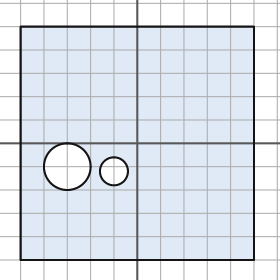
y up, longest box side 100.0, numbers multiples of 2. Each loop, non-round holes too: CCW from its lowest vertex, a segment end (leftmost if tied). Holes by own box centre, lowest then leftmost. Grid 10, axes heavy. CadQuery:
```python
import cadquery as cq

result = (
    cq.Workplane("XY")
    .moveTo(-50.0, -50.0)
    .lineTo(50.0, -50.0)
    .lineTo(50.0, 50.0)
    .lineTo(-50.0, 50.0)
    .close()
    .moveTo(-10.0, -12.0)
    .circle(6.0)
    .moveTo(-30.0, -10.0)
    .circle(10.0)
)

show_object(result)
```